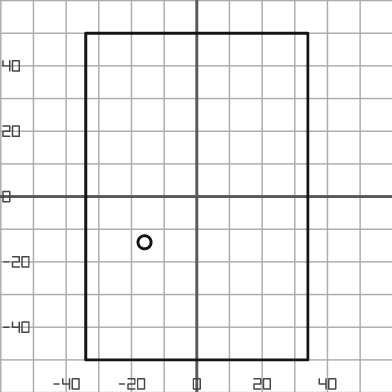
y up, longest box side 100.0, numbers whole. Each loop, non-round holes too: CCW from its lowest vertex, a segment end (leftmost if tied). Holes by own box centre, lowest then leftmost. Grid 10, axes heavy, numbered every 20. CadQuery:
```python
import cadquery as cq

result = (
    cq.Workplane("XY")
    .moveTo(-34.0, -50.0)
    .lineTo(34.0, -50.0)
    .lineTo(34.0, 50.0)
    .lineTo(-34.0, 50.0)
    .close()
    .moveTo(-16.0, -14.0)
    .circle(2.0)
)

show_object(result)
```